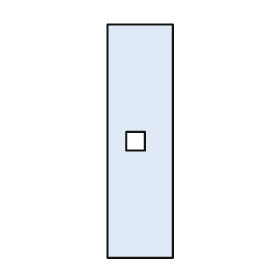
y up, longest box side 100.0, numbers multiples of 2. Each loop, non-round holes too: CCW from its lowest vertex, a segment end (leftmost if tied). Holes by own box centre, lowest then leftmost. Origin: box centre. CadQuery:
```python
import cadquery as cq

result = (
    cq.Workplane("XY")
    .moveTo(-14.0, -50.0)
    .lineTo(14.0, -50.0)
    .lineTo(14.0, 50.0)
    .lineTo(-14.0, 50.0)
    .close()
    .moveTo(-6.0, -4.0)
    .lineTo(2.0, -4.0)
    .lineTo(2.0, 4.0)
    .lineTo(-6.0, 4.0)
    .close()
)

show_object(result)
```